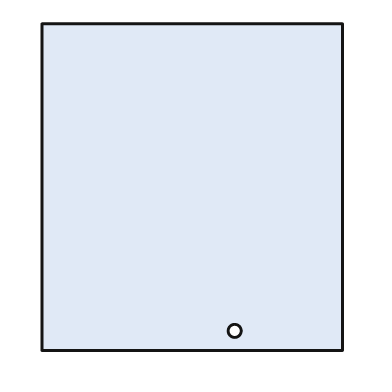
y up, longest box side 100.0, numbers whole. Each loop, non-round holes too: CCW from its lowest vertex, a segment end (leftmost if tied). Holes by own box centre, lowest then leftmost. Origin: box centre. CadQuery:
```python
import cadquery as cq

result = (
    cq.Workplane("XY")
    .moveTo(-46.0, -50.0)
    .lineTo(46.0, -50.0)
    .lineTo(46.0, 50.0)
    .lineTo(-46.0, 50.0)
    .close()
    .moveTo(13.0, -44.0)
    .circle(2.0)
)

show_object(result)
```